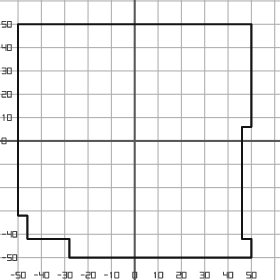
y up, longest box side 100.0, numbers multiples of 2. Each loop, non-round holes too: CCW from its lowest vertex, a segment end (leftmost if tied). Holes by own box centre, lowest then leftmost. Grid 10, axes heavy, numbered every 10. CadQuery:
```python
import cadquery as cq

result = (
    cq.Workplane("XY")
    .moveTo(-28.0, -50.0)
    .lineTo(50.0, -50.0)
    .lineTo(50.0, -42.0)
    .lineTo(46.0, -42.0)
    .lineTo(46.0, 6.0)
    .lineTo(50.0, 6.0)
    .lineTo(50.0, 50.0)
    .lineTo(-50.0, 50.0)
    .lineTo(-50.0, -32.0)
    .lineTo(-46.0, -32.0)
    .lineTo(-46.0, -42.0)
    .lineTo(-28.0, -42.0)
    .close()
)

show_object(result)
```